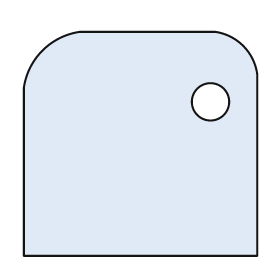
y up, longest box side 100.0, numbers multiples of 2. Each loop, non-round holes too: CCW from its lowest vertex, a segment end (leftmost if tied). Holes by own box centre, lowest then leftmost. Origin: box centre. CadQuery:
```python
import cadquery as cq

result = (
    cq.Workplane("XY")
    .moveTo(-50.0, -48.0)
    .lineTo(50.0, -48.0)
    .lineTo(50.0, 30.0)
    .threePointArc((44.0, 42.0), (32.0, 48.0))
    .lineTo(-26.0, 48.0)
    .threePointArc((-42.0, 40.0), (-50.0, 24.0))
    .close()
    .moveTo(30.0, 18.0)
    .circle(8.0)
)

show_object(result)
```